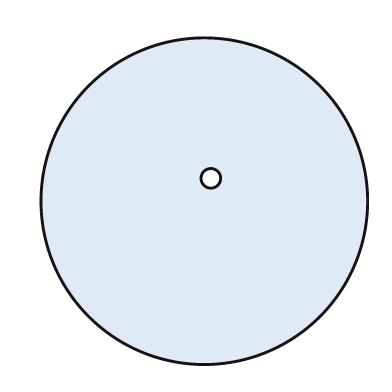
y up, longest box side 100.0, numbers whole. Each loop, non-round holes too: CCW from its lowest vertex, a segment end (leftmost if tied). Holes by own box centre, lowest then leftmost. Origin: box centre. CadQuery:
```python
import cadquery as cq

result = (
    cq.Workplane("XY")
    .moveTo(0.0, 0.0)
    .circle(50.0)
    .moveTo(2.0, 7.0)
    .circle(3.0)
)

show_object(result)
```